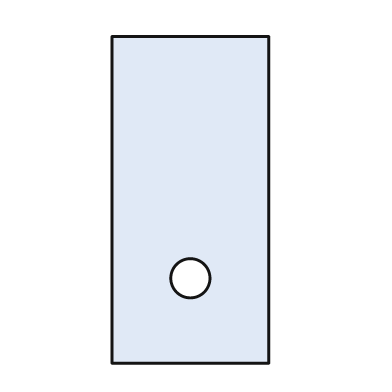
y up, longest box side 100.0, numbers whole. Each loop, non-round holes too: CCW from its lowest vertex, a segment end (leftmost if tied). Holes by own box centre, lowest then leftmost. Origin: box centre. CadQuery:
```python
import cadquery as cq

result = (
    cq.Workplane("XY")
    .moveTo(-24.0, -50.0)
    .lineTo(24.0, -50.0)
    .lineTo(24.0, 50.0)
    .lineTo(-24.0, 50.0)
    .close()
    .moveTo(0.0, -24.0)
    .circle(6.0)
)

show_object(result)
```